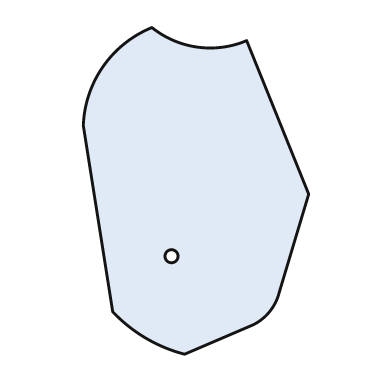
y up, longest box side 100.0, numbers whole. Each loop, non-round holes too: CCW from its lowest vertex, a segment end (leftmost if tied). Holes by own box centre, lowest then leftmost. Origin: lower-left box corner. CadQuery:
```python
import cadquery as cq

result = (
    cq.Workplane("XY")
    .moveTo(31.0, 0.0)
    .lineTo(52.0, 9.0)
    .threePointArc((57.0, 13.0), (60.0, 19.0))
    .lineTo(69.0, 49.0)
    .lineTo(50.0, 96.0)
    .threePointArc((35.0, 94.0), (21.0, 100.0))
    .threePointArc((6.0, 88.0), (0.0, 70.0))
    .lineTo(9.0, 13.0)
    .threePointArc((19.0, 5.0), (31.0, 0.0))
    .close()
    .moveTo(27.0, 30.0)
    .circle(2.0)
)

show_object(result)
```